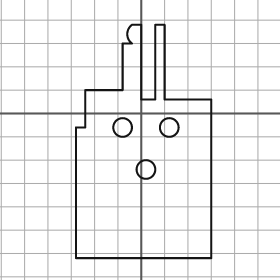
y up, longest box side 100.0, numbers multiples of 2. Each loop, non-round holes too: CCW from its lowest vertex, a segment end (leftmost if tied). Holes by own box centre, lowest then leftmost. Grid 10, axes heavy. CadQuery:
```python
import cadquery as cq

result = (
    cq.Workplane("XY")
    .moveTo(-28.0, -62.0)
    .lineTo(30.0, -62.0)
    .lineTo(30.0, 6.0)
    .lineTo(10.0, 6.0)
    .lineTo(10.0, 38.0)
    .lineTo(6.0, 38.0)
    .lineTo(6.0, 6.0)
    .lineTo(0.0, 6.0)
    .lineTo(0.0, 38.0)
    .lineTo(-4.0, 38.0)
    .threePointArc((-6.0, 34.0), (-4.0, 30.0))
    .lineTo(-8.0, 30.0)
    .lineTo(-8.0, 10.0)
    .lineTo(-24.0, 10.0)
    .lineTo(-24.0, -6.0)
    .lineTo(-28.0, -6.0)
    .close()
    .moveTo(2.0, -24.0)
    .circle(4.0)
    .moveTo(-8.0, -6.0)
    .circle(4.0)
    .moveTo(12.0, -6.0)
    .circle(4.0)
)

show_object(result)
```